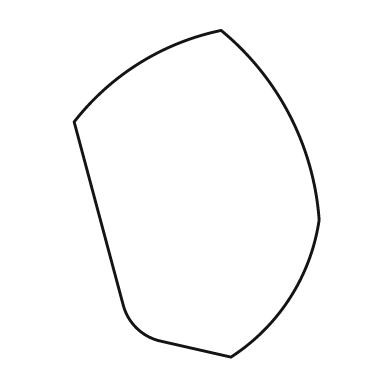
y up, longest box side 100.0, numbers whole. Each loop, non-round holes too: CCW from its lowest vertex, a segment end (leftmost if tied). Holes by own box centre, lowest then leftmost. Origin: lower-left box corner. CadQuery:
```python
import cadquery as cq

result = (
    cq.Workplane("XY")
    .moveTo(48.0, 0.0)
    .threePointArc((66.0, 18.0), (75.0, 42.0))
    .threePointArc((66.0, 74.0), (45.0, 100.0))
    .threePointArc((20.0, 90.0), (0.0, 72.0))
    .lineTo(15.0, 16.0)
    .threePointArc((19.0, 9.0), (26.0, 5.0))
    .close()
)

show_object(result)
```